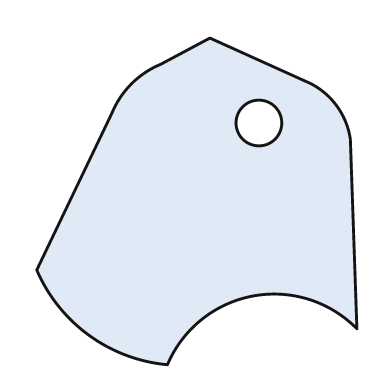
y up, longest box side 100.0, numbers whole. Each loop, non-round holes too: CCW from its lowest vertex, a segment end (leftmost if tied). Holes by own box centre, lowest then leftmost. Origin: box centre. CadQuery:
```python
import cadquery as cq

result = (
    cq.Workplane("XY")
    .moveTo(-9.0, -50.0)
    .threePointArc((17.0, -29.0), (49.0, -39.0))
    .lineTo(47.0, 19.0)
    .threePointArc((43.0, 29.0), (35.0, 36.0))
    .lineTo(4.0, 50.0)
    .lineTo(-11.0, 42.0)
    .threePointArc((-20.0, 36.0), (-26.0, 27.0))
    .lineTo(-49.0, -21.0)
    .threePointArc((-33.0, -41.0), (-9.0, -50.0))
    .close()
    .moveTo(19.0, 24.0)
    .circle(7.0)
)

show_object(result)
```